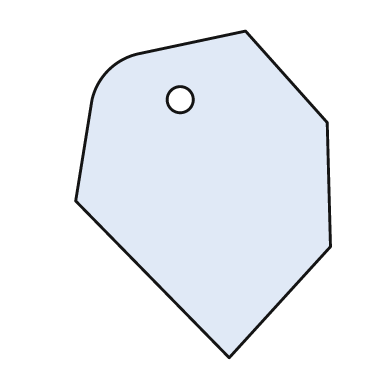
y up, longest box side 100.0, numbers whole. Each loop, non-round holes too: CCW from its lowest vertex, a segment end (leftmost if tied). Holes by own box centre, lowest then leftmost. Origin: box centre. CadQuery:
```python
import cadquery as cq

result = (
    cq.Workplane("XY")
    .moveTo(8.0, -50.0)
    .lineTo(39.0, -16.0)
    .lineTo(38.0, 22.0)
    .lineTo(13.0, 50.0)
    .lineTo(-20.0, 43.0)
    .threePointArc((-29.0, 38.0), (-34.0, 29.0))
    .lineTo(-39.0, -2.0)
    .close()
    .moveTo(-7.0, 29.0)
    .circle(4.0)
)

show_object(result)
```